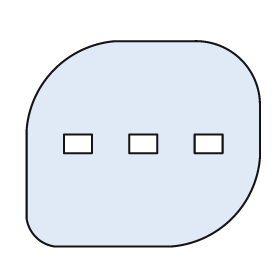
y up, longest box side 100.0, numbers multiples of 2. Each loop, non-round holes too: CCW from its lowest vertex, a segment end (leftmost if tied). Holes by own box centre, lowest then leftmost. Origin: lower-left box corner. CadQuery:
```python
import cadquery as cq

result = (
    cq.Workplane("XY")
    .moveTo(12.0, 0.0)
    .lineTo(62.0, 0.0)
    .threePointArc((88.0, 12.0), (100.0, 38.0))
    .lineTo(100.0, 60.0)
    .threePointArc((92.0, 80.0), (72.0, 88.0))
    .lineTo(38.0, 88.0)
    .threePointArc((12.0, 76.0), (0.0, 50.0))
    .lineTo(0.0, 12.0)
    .threePointArc((4.0, 4.0), (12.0, 0.0))
    .close()
    .moveTo(16.0, 40.0)
    .lineTo(28.0, 40.0)
    .lineTo(28.0, 48.0)
    .lineTo(16.0, 48.0)
    .close()
    .moveTo(44.0, 40.0)
    .lineTo(56.0, 40.0)
    .lineTo(56.0, 48.0)
    .lineTo(44.0, 48.0)
    .close()
    .moveTo(72.0, 40.0)
    .lineTo(84.0, 40.0)
    .lineTo(84.0, 48.0)
    .lineTo(72.0, 48.0)
    .close()
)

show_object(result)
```